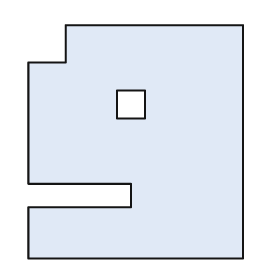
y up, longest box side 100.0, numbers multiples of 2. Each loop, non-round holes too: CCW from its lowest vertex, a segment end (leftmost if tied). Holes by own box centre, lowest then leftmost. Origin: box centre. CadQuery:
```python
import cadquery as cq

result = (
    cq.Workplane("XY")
    .moveTo(-46.0, -50.0)
    .lineTo(46.0, -50.0)
    .lineTo(46.0, 50.0)
    .lineTo(-30.0, 50.0)
    .lineTo(-30.0, 34.0)
    .lineTo(-46.0, 34.0)
    .lineTo(-46.0, -18.0)
    .lineTo(-2.0, -18.0)
    .lineTo(-2.0, -28.0)
    .lineTo(-46.0, -28.0)
    .close()
    .moveTo(-8.0, 10.0)
    .lineTo(4.0, 10.0)
    .lineTo(4.0, 22.0)
    .lineTo(-8.0, 22.0)
    .close()
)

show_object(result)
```